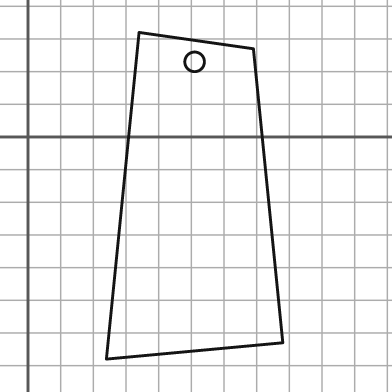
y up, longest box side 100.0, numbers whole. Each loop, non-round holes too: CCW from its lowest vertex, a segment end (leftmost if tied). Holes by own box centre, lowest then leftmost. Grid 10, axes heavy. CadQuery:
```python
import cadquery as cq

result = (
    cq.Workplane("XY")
    .moveTo(24.0, -68.0)
    .lineTo(78.0, -63.0)
    .lineTo(69.0, 27.0)
    .lineTo(34.0, 32.0)
    .close()
    .moveTo(51.0, 23.0)
    .circle(3.0)
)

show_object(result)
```